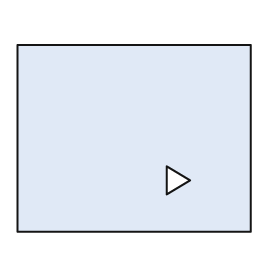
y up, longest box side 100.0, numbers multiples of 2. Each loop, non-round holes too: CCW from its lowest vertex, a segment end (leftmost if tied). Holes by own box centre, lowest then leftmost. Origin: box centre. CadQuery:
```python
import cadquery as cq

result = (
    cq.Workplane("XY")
    .moveTo(-50.0, -40.0)
    .lineTo(50.0, -40.0)
    .lineTo(50.0, 40.0)
    .lineTo(-50.0, 40.0)
    .close()
    .moveTo(14.0, -24.0)
    .lineTo(24.0, -18.0)
    .lineTo(14.0, -12.0)
    .close()
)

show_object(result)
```